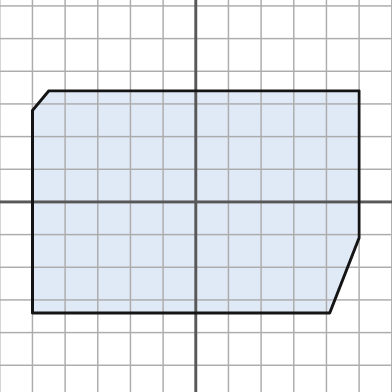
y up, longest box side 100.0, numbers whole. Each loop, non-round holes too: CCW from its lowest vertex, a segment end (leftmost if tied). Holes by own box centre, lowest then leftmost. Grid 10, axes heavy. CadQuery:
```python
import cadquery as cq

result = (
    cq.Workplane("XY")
    .moveTo(-50.0, -34.0)
    .lineTo(41.0, -34.0)
    .lineTo(50.0, -11.0)
    .lineTo(50.0, 34.0)
    .lineTo(-45.0, 34.0)
    .lineTo(-50.0, 28.0)
    .close()
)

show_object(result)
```